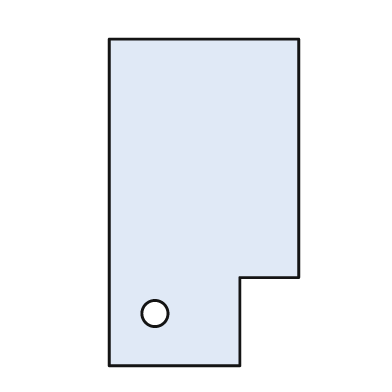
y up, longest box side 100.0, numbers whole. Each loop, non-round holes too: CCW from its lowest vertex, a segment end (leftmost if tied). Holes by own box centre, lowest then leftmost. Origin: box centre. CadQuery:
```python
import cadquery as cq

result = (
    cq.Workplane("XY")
    .moveTo(-29.0, -50.0)
    .lineTo(11.0, -50.0)
    .lineTo(11.0, -23.0)
    .lineTo(29.0, -23.0)
    .lineTo(29.0, 50.0)
    .lineTo(-29.0, 50.0)
    .close()
    .moveTo(-15.0, -34.0)
    .circle(4.0)
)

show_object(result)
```